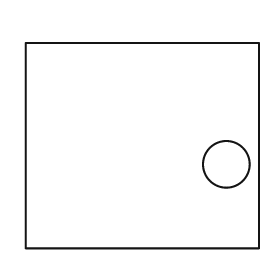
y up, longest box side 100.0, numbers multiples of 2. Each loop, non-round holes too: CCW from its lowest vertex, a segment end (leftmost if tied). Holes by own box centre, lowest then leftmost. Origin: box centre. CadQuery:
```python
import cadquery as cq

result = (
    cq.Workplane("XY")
    .moveTo(-50.0, -44.0)
    .lineTo(50.0, -44.0)
    .lineTo(50.0, 44.0)
    .lineTo(-50.0, 44.0)
    .close()
    .moveTo(36.0, -8.0)
    .circle(10.0)
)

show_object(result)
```